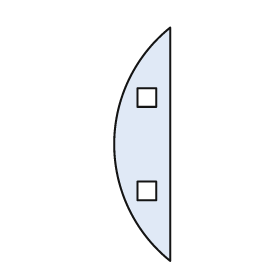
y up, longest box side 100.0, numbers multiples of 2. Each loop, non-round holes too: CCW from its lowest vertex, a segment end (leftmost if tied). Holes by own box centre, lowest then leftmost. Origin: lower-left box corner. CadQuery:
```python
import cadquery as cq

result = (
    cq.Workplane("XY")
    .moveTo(24.0, 0.0)
    .lineTo(24.0, 100.0)
    .threePointArc((0.0, 50.0), (24.0, 0.0))
    .close()
    .moveTo(10.0, 26.0)
    .lineTo(18.0, 26.0)
    .lineTo(18.0, 34.0)
    .lineTo(10.0, 34.0)
    .close()
    .moveTo(10.0, 66.0)
    .lineTo(18.0, 66.0)
    .lineTo(18.0, 74.0)
    .lineTo(10.0, 74.0)
    .close()
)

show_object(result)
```